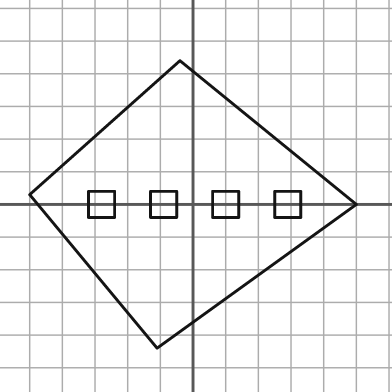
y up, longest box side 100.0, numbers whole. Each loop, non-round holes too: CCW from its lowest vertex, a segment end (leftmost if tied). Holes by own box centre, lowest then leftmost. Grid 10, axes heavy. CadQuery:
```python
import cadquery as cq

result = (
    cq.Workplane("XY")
    .moveTo(-11.0, -44.0)
    .lineTo(50.0, 0.0)
    .lineTo(-4.0, 44.0)
    .lineTo(-50.0, 3.0)
    .close()
    .moveTo(-32.0, -4.0)
    .lineTo(-24.0, -4.0)
    .lineTo(-24.0, 4.0)
    .lineTo(-32.0, 4.0)
    .close()
    .moveTo(-13.0, -4.0)
    .lineTo(-5.0, -4.0)
    .lineTo(-5.0, 4.0)
    .lineTo(-13.0, 4.0)
    .close()
    .moveTo(6.0, -4.0)
    .lineTo(14.0, -4.0)
    .lineTo(14.0, 4.0)
    .lineTo(6.0, 4.0)
    .close()
    .moveTo(25.0, -4.0)
    .lineTo(33.0, -4.0)
    .lineTo(33.0, 4.0)
    .lineTo(25.0, 4.0)
    .close()
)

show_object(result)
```